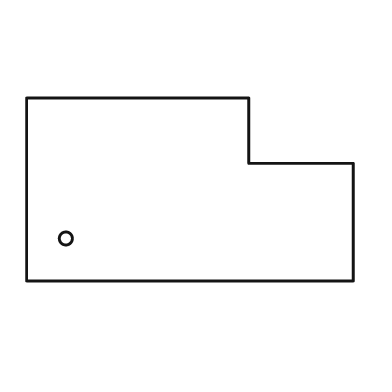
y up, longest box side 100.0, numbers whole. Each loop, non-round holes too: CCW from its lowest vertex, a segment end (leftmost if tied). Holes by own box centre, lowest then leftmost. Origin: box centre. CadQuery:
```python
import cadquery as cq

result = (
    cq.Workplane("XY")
    .moveTo(-50.0, -28.0)
    .lineTo(50.0, -28.0)
    .lineTo(50.0, 8.0)
    .lineTo(18.0, 8.0)
    .lineTo(18.0, 28.0)
    .lineTo(-50.0, 28.0)
    .close()
    .moveTo(-38.0, -15.0)
    .circle(2.0)
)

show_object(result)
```